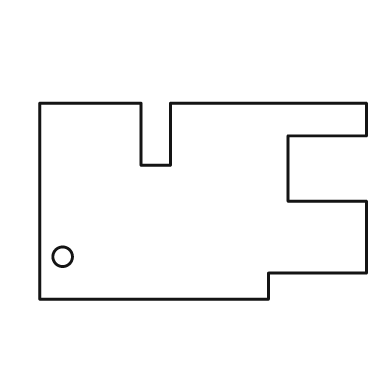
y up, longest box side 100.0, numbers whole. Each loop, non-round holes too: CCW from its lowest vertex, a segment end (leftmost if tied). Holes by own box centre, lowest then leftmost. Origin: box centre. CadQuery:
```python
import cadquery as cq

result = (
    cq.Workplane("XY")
    .moveTo(-50.0, -30.0)
    .lineTo(20.0, -30.0)
    .lineTo(20.0, -22.0)
    .lineTo(50.0, -22.0)
    .lineTo(50.0, 0.0)
    .lineTo(26.0, 0.0)
    .lineTo(26.0, 20.0)
    .lineTo(50.0, 20.0)
    .lineTo(50.0, 30.0)
    .lineTo(-10.0, 30.0)
    .lineTo(-10.0, 11.0)
    .lineTo(-19.0, 11.0)
    .lineTo(-19.0, 30.0)
    .lineTo(-50.0, 30.0)
    .close()
    .moveTo(-43.0, -17.0)
    .circle(3.0)
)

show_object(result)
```